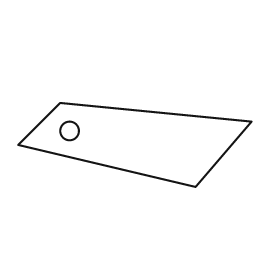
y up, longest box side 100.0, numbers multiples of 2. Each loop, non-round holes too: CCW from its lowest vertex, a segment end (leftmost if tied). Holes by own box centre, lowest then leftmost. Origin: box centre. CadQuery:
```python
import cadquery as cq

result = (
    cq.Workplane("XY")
    .moveTo(26.0, -18.0)
    .lineTo(50.0, 10.0)
    .lineTo(-32.0, 18.0)
    .lineTo(-50.0, 0.0)
    .close()
    .moveTo(-28.0, 6.0)
    .circle(4.0)
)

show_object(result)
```